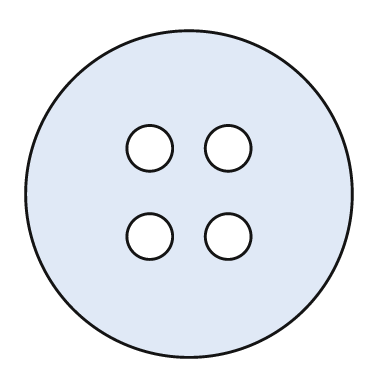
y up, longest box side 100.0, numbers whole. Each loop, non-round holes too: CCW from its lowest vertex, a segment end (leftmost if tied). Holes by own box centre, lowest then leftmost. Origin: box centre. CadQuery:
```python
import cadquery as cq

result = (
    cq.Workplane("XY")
    .moveTo(0.0, 0.0)
    .circle(50.0)
    .moveTo(-12.0, -13.0)
    .circle(7.0)
    .moveTo(12.0, -13.0)
    .circle(7.0)
    .moveTo(-12.0, 14.0)
    .circle(7.0)
    .moveTo(12.0, 14.0)
    .circle(7.0)
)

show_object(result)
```